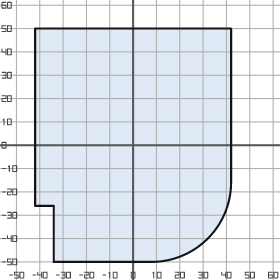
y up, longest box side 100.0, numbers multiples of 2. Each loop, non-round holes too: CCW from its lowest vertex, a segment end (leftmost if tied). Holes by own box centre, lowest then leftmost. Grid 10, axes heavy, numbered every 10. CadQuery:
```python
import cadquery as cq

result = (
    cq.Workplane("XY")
    .moveTo(-34.0, -50.0)
    .lineTo(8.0, -50.0)
    .threePointArc((32.0, -40.0), (42.0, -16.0))
    .lineTo(42.0, 50.0)
    .lineTo(-42.0, 50.0)
    .lineTo(-42.0, -26.0)
    .lineTo(-34.0, -26.0)
    .close()
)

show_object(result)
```